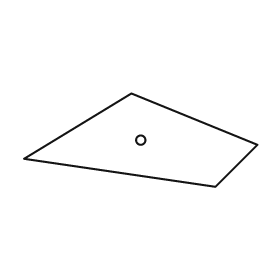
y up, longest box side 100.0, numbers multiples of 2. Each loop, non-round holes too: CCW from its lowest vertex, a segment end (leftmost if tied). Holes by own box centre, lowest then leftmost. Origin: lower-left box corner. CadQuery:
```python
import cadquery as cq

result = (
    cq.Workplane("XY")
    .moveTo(82.0, 0.0)
    .lineTo(100.0, 18.0)
    .lineTo(46.0, 40.0)
    .lineTo(0.0, 12.0)
    .close()
    .moveTo(50.0, 20.0)
    .circle(2.0)
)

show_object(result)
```